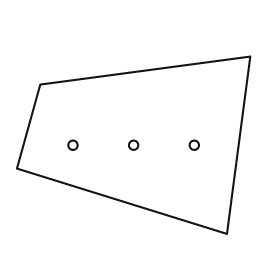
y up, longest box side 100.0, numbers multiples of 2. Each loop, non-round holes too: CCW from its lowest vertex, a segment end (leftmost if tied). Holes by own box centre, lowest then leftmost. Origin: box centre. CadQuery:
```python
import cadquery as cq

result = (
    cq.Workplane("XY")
    .moveTo(40.0, -38.0)
    .lineTo(50.0, 38.0)
    .lineTo(-40.0, 26.0)
    .lineTo(-50.0, -10.0)
    .close()
    .moveTo(-26.0, 0.0)
    .circle(2.0)
    .moveTo(0.0, 0.0)
    .circle(2.0)
    .moveTo(26.0, 0.0)
    .circle(2.0)
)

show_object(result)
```